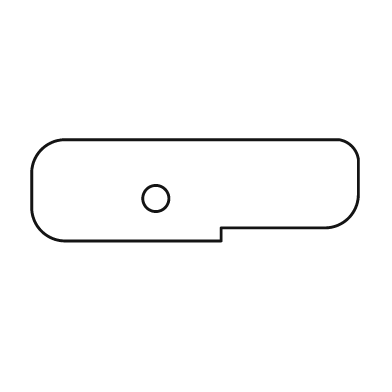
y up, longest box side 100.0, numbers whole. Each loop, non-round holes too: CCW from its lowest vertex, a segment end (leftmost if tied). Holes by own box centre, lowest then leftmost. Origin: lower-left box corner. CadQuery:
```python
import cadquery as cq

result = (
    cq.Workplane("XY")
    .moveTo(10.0, 0.0)
    .lineTo(58.0, 0.0)
    .lineTo(58.0, 4.0)
    .lineTo(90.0, 4.0)
    .threePointArc((97.0, 7.0), (100.0, 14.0))
    .lineTo(100.0, 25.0)
    .threePointArc((98.0, 29.0), (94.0, 31.0))
    .lineTo(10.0, 31.0)
    .threePointArc((3.0, 28.0), (0.0, 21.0))
    .lineTo(0.0, 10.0)
    .threePointArc((3.0, 3.0), (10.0, 0.0))
    .close()
    .moveTo(38.0, 13.0)
    .circle(4.0)
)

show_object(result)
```